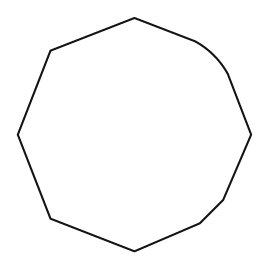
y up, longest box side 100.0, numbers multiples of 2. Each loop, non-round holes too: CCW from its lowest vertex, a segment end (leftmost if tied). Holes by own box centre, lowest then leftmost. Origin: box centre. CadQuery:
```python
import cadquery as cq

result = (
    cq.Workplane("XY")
    .moveTo(0.0, -50.0)
    .lineTo(28.0, -38.0)
    .lineTo(38.0, -28.0)
    .lineTo(50.0, 0.0)
    .lineTo(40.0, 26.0)
    .threePointArc((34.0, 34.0), (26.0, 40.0))
    .lineTo(0.0, 50.0)
    .lineTo(-36.0, 36.0)
    .lineTo(-50.0, 0.0)
    .lineTo(-36.0, -36.0)
    .close()
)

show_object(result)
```